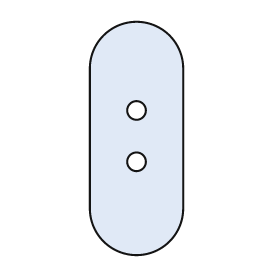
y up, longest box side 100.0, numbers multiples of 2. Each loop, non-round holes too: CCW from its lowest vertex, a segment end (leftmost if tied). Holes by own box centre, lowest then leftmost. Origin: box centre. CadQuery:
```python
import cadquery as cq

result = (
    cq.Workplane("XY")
    .moveTo(-20.0, -30.0)
    .threePointArc((0.0, -50.0), (20.0, -30.0))
    .lineTo(20.0, 30.0)
    .threePointArc((0.0, 50.0), (-20.0, 30.0))
    .close()
    .moveTo(0.0, -10.0)
    .circle(4.0)
    .moveTo(0.0, 12.0)
    .circle(4.0)
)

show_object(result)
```